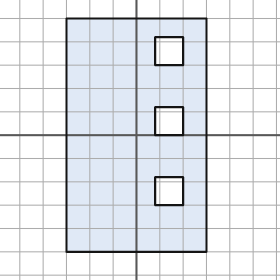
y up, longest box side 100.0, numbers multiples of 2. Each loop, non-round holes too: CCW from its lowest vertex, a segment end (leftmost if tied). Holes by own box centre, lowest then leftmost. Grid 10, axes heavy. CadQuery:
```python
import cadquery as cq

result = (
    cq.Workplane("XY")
    .moveTo(-30.0, -50.0)
    .lineTo(30.0, -50.0)
    .lineTo(30.0, 50.0)
    .lineTo(-30.0, 50.0)
    .close()
    .moveTo(8.0, -30.0)
    .lineTo(20.0, -30.0)
    .lineTo(20.0, -18.0)
    .lineTo(8.0, -18.0)
    .close()
    .moveTo(8.0, 0.0)
    .lineTo(20.0, 0.0)
    .lineTo(20.0, 12.0)
    .lineTo(8.0, 12.0)
    .close()
    .moveTo(8.0, 30.0)
    .lineTo(20.0, 30.0)
    .lineTo(20.0, 42.0)
    .lineTo(8.0, 42.0)
    .close()
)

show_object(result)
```